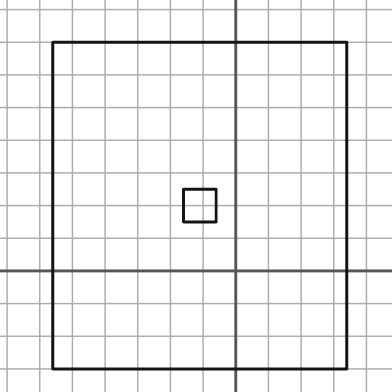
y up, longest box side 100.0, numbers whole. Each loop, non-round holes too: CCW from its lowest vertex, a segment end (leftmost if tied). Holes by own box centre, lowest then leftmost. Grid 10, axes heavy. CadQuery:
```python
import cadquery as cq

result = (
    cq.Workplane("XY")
    .moveTo(-56.0, -30.0)
    .lineTo(34.0, -30.0)
    .lineTo(34.0, 70.0)
    .lineTo(-56.0, 70.0)
    .close()
    .moveTo(-16.0, 15.0)
    .lineTo(-6.0, 15.0)
    .lineTo(-6.0, 25.0)
    .lineTo(-16.0, 25.0)
    .close()
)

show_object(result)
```